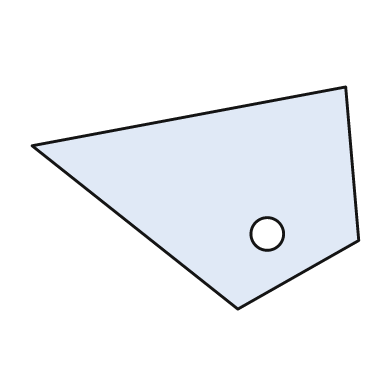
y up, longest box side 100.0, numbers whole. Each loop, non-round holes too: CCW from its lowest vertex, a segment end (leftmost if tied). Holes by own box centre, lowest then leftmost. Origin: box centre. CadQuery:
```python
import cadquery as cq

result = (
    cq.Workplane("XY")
    .moveTo(13.0, -34.0)
    .lineTo(50.0, -13.0)
    .lineTo(46.0, 34.0)
    .lineTo(-50.0, 16.0)
    .close()
    .moveTo(22.0, -11.0)
    .circle(5.0)
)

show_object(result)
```